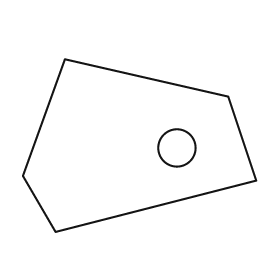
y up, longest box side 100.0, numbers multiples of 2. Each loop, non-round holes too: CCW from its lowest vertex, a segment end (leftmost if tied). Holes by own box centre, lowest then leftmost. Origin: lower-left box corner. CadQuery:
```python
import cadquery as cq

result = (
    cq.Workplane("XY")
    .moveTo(14.0, 0.0)
    .lineTo(100.0, 22.0)
    .lineTo(88.0, 58.0)
    .lineTo(18.0, 74.0)
    .lineTo(0.0, 24.0)
    .close()
    .moveTo(66.0, 36.0)
    .circle(8.0)
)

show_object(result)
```